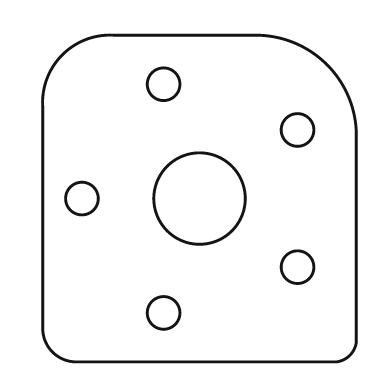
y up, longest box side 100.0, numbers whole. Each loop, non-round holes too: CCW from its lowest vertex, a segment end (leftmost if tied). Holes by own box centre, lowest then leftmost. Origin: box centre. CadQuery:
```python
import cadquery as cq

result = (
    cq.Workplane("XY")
    .moveTo(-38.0, -50.0)
    .lineTo(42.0, -50.0)
    .threePointArc((46.0, -48.0), (48.0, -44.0))
    .lineTo(48.0, 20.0)
    .threePointArc((39.0, 41.0), (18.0, 50.0))
    .lineTo(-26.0, 50.0)
    .threePointArc((-42.0, 44.0), (-48.0, 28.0))
    .lineTo(-48.0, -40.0)
    .threePointArc((-45.0, -47.0), (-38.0, -50.0))
    .close()
    .moveTo(-11.0, -35.0)
    .circle(5.0)
    .moveTo(30.0, -21.0)
    .circle(5.0)
    .moveTo(-36.0, 0.0)
    .circle(5.0)
    .moveTo(0.0, 0.0)
    .circle(14.0)
    .moveTo(30.0, 21.0)
    .circle(5.0)
    .moveTo(-11.0, 35.0)
    .circle(5.0)
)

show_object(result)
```